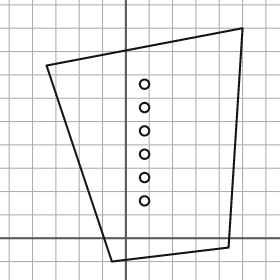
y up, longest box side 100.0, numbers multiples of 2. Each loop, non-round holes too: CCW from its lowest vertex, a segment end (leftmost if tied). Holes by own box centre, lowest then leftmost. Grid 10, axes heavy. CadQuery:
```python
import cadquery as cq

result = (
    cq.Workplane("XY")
    .moveTo(-6.0, -10.0)
    .lineTo(44.0, -4.0)
    .lineTo(50.0, 90.0)
    .lineTo(-34.0, 74.0)
    .close()
    .moveTo(8.0, 16.0)
    .circle(2.0)
    .moveTo(8.0, 26.0)
    .circle(2.0)
    .moveTo(8.0, 36.0)
    .circle(2.0)
    .moveTo(8.0, 46.0)
    .circle(2.0)
    .moveTo(8.0, 56.0)
    .circle(2.0)
    .moveTo(8.0, 66.0)
    .circle(2.0)
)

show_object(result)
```